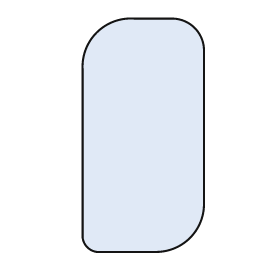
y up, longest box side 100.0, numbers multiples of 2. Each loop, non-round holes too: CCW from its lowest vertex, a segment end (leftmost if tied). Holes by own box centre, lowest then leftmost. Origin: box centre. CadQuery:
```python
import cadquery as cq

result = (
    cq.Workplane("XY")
    .moveTo(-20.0, -50.0)
    .lineTo(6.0, -50.0)
    .threePointArc((20.0, -44.0), (26.0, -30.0))
    .lineTo(26.0, 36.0)
    .threePointArc((22.0, 46.0), (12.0, 50.0))
    .lineTo(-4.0, 50.0)
    .threePointArc((-20.0, 44.0), (-26.0, 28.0))
    .lineTo(-26.0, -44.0)
    .threePointArc((-24.0, -48.0), (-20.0, -50.0))
    .close()
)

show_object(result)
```